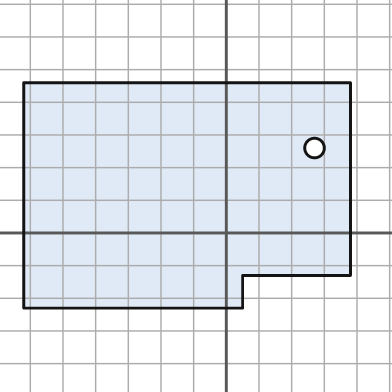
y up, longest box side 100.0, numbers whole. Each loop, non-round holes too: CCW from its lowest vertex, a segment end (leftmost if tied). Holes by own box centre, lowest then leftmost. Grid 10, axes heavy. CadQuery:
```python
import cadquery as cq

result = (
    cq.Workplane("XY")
    .moveTo(-62.0, -23.0)
    .lineTo(5.0, -23.0)
    .lineTo(5.0, -13.0)
    .lineTo(38.0, -13.0)
    .lineTo(38.0, 46.0)
    .lineTo(-62.0, 46.0)
    .close()
    .moveTo(27.0, 26.0)
    .circle(3.0)
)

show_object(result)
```